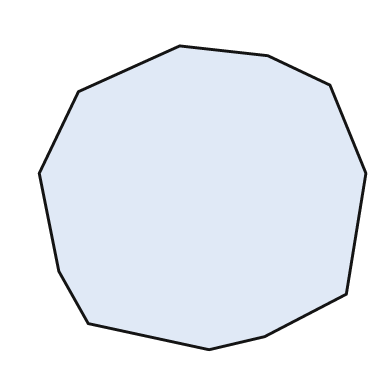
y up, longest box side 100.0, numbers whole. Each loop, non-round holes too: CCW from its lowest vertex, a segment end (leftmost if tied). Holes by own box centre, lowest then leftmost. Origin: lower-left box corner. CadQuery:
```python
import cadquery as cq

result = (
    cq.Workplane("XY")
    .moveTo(52.0, 0.0)
    .lineTo(69.0, 4.0)
    .lineTo(94.0, 17.0)
    .lineTo(100.0, 54.0)
    .lineTo(89.0, 81.0)
    .lineTo(70.0, 90.0)
    .lineTo(43.0, 93.0)
    .lineTo(12.0, 79.0)
    .lineTo(0.0, 54.0)
    .lineTo(6.0, 24.0)
    .lineTo(15.0, 8.0)
    .close()
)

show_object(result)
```